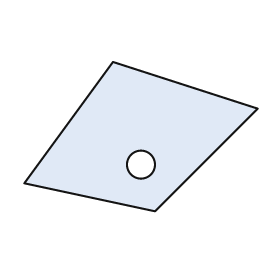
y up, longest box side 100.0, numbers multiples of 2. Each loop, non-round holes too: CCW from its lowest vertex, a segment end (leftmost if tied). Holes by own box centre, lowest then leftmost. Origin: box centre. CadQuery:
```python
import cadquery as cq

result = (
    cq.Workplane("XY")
    .moveTo(6.0, -32.0)
    .lineTo(50.0, 12.0)
    .lineTo(-12.0, 32.0)
    .lineTo(-50.0, -20.0)
    .close()
    .moveTo(0.0, -12.0)
    .circle(6.0)
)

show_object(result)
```